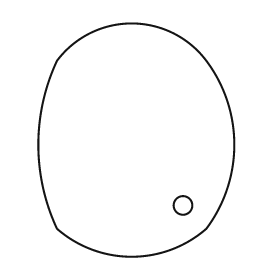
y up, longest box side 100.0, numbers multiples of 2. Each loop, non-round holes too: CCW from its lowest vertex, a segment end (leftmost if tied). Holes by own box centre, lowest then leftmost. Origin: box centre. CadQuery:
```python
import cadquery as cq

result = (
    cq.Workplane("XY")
    .moveTo(-34.0, -38.0)
    .threePointArc((-2.0, -50.0), (30.0, -38.0))
    .threePointArc((42.0, -2.0), (30.0, 34.0))
    .threePointArc((-2.0, 50.0), (-34.0, 34.0))
    .threePointArc((-42.0, -2.0), (-34.0, -38.0))
    .close()
    .moveTo(20.0, -28.0)
    .circle(4.0)
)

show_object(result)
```